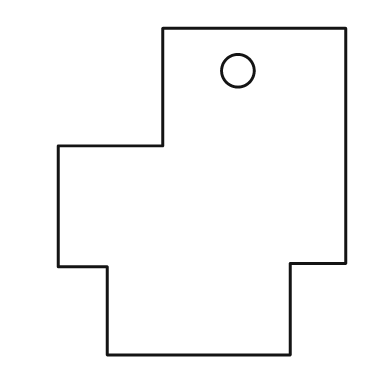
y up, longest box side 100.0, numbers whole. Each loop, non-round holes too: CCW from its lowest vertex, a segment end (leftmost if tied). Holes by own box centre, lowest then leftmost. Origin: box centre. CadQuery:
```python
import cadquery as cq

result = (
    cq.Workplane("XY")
    .moveTo(-29.0, -50.0)
    .lineTo(27.0, -50.0)
    .lineTo(27.0, -22.0)
    .lineTo(44.0, -22.0)
    .lineTo(44.0, 50.0)
    .lineTo(-12.0, 50.0)
    .lineTo(-12.0, 14.0)
    .lineTo(-44.0, 14.0)
    .lineTo(-44.0, -23.0)
    .lineTo(-29.0, -23.0)
    .close()
    .moveTo(11.0, 37.0)
    .circle(5.0)
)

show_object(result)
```